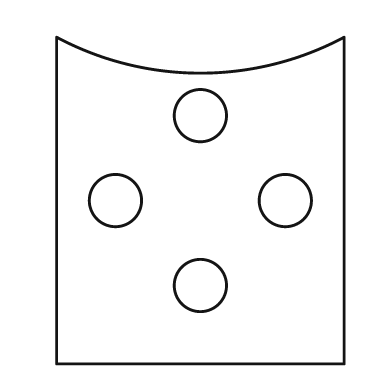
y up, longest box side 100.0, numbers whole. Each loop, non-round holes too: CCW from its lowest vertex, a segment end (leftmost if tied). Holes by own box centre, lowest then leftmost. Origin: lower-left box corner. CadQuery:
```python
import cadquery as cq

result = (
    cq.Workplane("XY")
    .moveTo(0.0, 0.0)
    .lineTo(88.0, 0.0)
    .lineTo(88.0, 100.0)
    .threePointArc((44.0, 89.0), (0.0, 100.0))
    .close()
    .moveTo(44.0, 24.0)
    .circle(8.0)
    .moveTo(18.0, 50.0)
    .circle(8.0)
    .moveTo(70.0, 50.0)
    .circle(8.0)
    .moveTo(44.0, 76.0)
    .circle(8.0)
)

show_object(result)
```